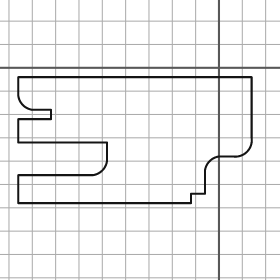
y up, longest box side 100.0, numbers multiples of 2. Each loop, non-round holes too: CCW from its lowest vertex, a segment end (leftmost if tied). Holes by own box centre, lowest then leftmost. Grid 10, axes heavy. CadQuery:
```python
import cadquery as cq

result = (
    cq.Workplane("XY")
    .moveTo(-86.0, -58.0)
    .lineTo(-12.0, -58.0)
    .lineTo(-12.0, -54.0)
    .lineTo(-6.0, -54.0)
    .lineTo(-6.0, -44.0)
    .threePointArc((-4.0, -40.0), (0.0, -38.0))
    .lineTo(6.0, -38.0)
    .threePointArc((12.0, -36.0), (14.0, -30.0))
    .lineTo(14.0, -4.0)
    .lineTo(-86.0, -4.0)
    .lineTo(-86.0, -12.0)
    .threePointArc((-84.0, -16.0), (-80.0, -18.0))
    .lineTo(-72.0, -18.0)
    .lineTo(-72.0, -22.0)
    .lineTo(-86.0, -22.0)
    .lineTo(-86.0, -32.0)
    .lineTo(-48.0, -32.0)
    .lineTo(-48.0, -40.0)
    .threePointArc((-50.0, -44.0), (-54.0, -46.0))
    .lineTo(-86.0, -46.0)
    .close()
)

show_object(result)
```